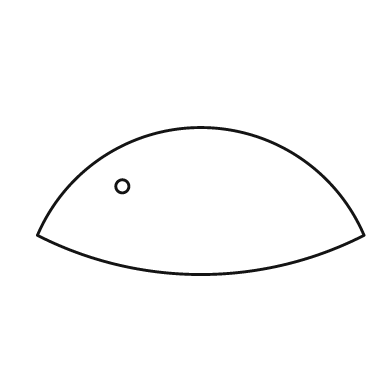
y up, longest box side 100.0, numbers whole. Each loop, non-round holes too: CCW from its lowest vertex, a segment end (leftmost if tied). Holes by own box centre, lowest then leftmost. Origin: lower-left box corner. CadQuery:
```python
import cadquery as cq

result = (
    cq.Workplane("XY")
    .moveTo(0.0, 12.0)
    .threePointArc((50.0, 0.0), (100.0, 12.0))
    .threePointArc((50.0, 45.0), (0.0, 12.0))
    .close()
    .moveTo(26.0, 27.0)
    .circle(2.0)
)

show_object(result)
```